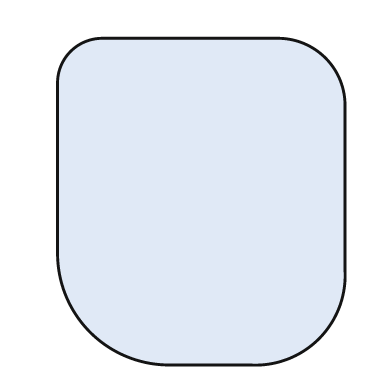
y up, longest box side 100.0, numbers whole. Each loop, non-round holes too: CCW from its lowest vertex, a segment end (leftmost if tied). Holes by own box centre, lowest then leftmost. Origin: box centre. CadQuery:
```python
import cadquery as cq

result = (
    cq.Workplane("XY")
    .moveTo(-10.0, -50.0)
    .lineTo(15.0, -50.0)
    .threePointArc((36.0, -42.0), (44.0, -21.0))
    .lineTo(44.0, 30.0)
    .threePointArc((38.0, 44.0), (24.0, 50.0))
    .lineTo(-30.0, 50.0)
    .threePointArc((-40.0, 46.0), (-44.0, 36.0))
    .lineTo(-44.0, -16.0)
    .threePointArc((-34.0, -40.0), (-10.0, -50.0))
    .close()
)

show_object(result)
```